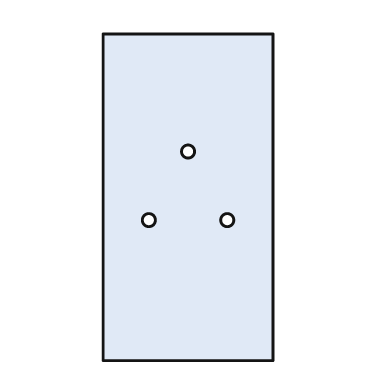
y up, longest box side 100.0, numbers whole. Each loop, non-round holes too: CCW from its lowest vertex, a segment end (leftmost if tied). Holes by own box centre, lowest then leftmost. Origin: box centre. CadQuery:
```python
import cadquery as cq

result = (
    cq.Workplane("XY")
    .moveTo(-26.0, -50.0)
    .lineTo(26.0, -50.0)
    .lineTo(26.0, 50.0)
    .lineTo(-26.0, 50.0)
    .close()
    .moveTo(-12.0, -7.0)
    .circle(2.0)
    .moveTo(12.0, -7.0)
    .circle(2.0)
    .moveTo(0.0, 14.0)
    .circle(2.0)
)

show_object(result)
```